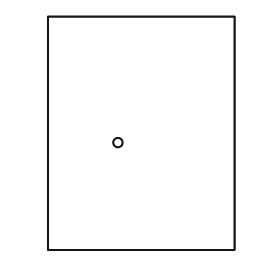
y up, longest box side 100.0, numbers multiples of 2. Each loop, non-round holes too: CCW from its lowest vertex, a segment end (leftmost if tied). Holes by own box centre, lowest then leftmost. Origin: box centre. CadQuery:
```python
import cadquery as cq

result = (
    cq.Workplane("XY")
    .moveTo(-40.0, -50.0)
    .lineTo(40.0, -50.0)
    .lineTo(40.0, 50.0)
    .lineTo(-40.0, 50.0)
    .close()
    .moveTo(-10.0, -4.0)
    .circle(2.0)
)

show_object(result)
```